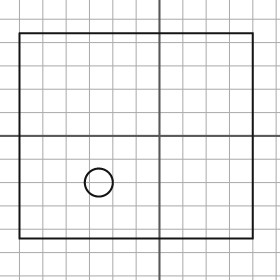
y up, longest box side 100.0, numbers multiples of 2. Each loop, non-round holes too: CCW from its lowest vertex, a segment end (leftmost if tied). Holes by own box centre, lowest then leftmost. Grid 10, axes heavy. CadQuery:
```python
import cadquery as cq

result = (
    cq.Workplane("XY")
    .moveTo(-60.0, -44.0)
    .lineTo(40.0, -44.0)
    .lineTo(40.0, 44.0)
    .lineTo(-60.0, 44.0)
    .close()
    .moveTo(-26.0, -20.0)
    .circle(6.0)
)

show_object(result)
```